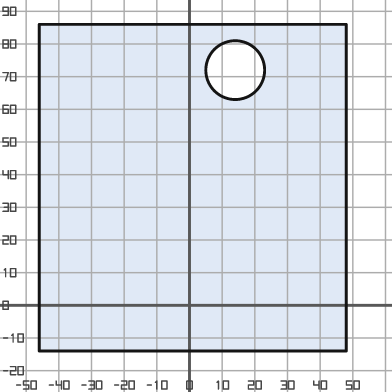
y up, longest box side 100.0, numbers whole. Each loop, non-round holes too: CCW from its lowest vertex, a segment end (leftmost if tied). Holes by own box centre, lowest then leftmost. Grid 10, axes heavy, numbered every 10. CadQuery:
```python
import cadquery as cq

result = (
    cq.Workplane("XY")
    .moveTo(-46.0, -14.0)
    .lineTo(48.0, -14.0)
    .lineTo(48.0, 86.0)
    .lineTo(-46.0, 86.0)
    .close()
    .moveTo(14.0, 72.0)
    .circle(9.0)
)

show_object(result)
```